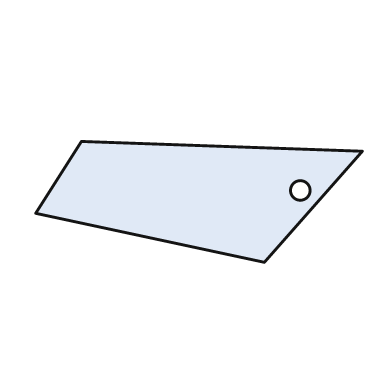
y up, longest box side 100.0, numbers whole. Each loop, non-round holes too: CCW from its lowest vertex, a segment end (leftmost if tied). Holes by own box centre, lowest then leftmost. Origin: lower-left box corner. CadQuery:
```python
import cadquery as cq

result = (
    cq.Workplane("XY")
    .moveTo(70.0, 0.0)
    .lineTo(100.0, 34.0)
    .lineTo(14.0, 37.0)
    .lineTo(0.0, 15.0)
    .close()
    .moveTo(81.0, 22.0)
    .circle(3.0)
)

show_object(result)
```